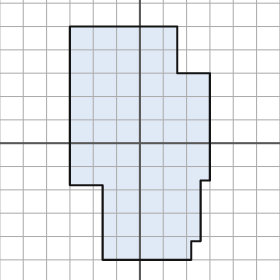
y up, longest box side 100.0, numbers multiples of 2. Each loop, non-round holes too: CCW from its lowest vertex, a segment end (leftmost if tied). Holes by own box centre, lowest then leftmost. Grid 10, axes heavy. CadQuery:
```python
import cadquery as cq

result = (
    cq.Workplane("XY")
    .moveTo(-16.0, -50.0)
    .lineTo(22.0, -50.0)
    .lineTo(22.0, -42.0)
    .lineTo(26.0, -42.0)
    .lineTo(26.0, -16.0)
    .lineTo(30.0, -16.0)
    .lineTo(30.0, 30.0)
    .lineTo(16.0, 30.0)
    .lineTo(16.0, 50.0)
    .lineTo(-30.0, 50.0)
    .lineTo(-30.0, -18.0)
    .lineTo(-16.0, -18.0)
    .close()
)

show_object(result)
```